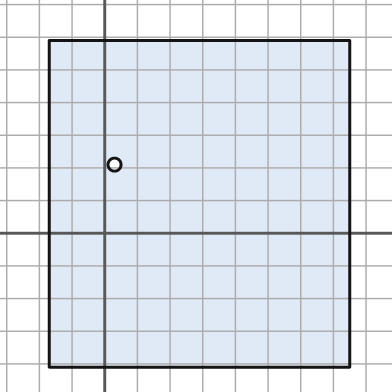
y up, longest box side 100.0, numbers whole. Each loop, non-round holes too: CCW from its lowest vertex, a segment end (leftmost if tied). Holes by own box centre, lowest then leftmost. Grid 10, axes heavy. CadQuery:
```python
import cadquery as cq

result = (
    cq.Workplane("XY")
    .moveTo(-17.0, -41.0)
    .lineTo(75.0, -41.0)
    .lineTo(75.0, 59.0)
    .lineTo(-17.0, 59.0)
    .close()
    .moveTo(3.0, 21.0)
    .circle(2.0)
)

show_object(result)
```